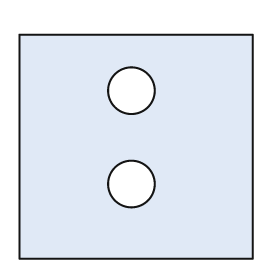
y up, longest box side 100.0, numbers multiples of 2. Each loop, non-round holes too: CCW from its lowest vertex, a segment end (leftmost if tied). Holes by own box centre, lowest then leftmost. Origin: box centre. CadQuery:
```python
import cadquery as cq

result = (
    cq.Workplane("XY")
    .moveTo(-50.0, -48.0)
    .lineTo(50.0, -48.0)
    .lineTo(50.0, 48.0)
    .lineTo(-50.0, 48.0)
    .close()
    .moveTo(-2.0, -16.0)
    .circle(10.0)
    .moveTo(-2.0, 24.0)
    .circle(10.0)
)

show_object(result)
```